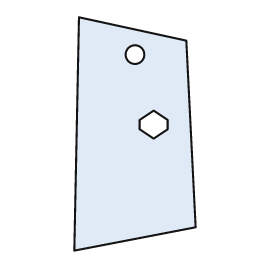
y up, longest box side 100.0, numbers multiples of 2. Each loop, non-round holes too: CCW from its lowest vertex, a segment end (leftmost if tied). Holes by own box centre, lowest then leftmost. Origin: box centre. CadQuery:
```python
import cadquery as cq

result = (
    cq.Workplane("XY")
    .moveTo(-26.0, -50.0)
    .lineTo(26.0, -40.0)
    .lineTo(22.0, 40.0)
    .lineTo(-24.0, 50.0)
    .close()
    .moveTo(8.0, -2.0)
    .lineTo(14.0, 2.0)
    .lineTo(14.0, 6.0)
    .lineTo(8.0, 10.0)
    .lineTo(2.0, 6.0)
    .lineTo(2.0, 2.0)
    .close()
    .moveTo(0.0, 34.0)
    .circle(4.0)
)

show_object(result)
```